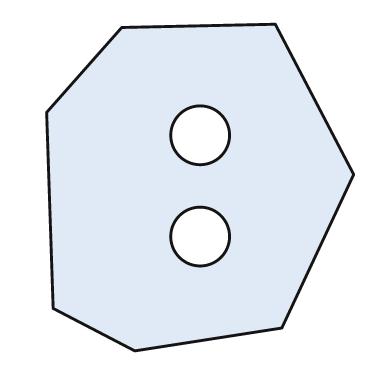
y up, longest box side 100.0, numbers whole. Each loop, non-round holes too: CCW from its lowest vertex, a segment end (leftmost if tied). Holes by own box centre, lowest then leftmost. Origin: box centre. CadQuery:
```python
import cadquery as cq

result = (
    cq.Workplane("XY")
    .moveTo(-20.0, -50.0)
    .lineTo(25.0, -43.0)
    .lineTo(47.0, 4.0)
    .lineTo(23.0, 50.0)
    .lineTo(-24.0, 49.0)
    .lineTo(-47.0, 23.0)
    .lineTo(-45.0, -37.0)
    .close()
    .moveTo(0.0, -15.0)
    .circle(9.0)
    .moveTo(0.0, 16.0)
    .circle(9.0)
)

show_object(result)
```